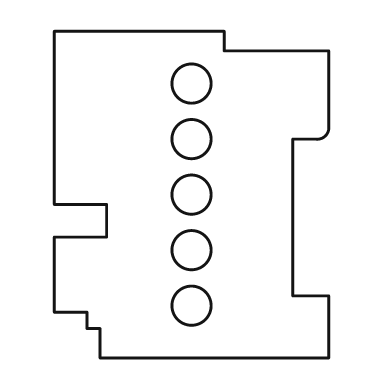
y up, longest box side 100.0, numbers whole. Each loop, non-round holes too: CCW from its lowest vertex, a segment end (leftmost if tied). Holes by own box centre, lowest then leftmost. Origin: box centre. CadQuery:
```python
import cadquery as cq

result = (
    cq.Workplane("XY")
    .moveTo(-28.0, -50.0)
    .lineTo(42.0, -50.0)
    .lineTo(42.0, -31.0)
    .lineTo(31.0, -31.0)
    .lineTo(31.0, 17.0)
    .lineTo(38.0, 17.0)
    .threePointArc((41.0, 18.0), (42.0, 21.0))
    .lineTo(42.0, 44.0)
    .lineTo(10.0, 44.0)
    .lineTo(10.0, 50.0)
    .lineTo(-42.0, 50.0)
    .lineTo(-42.0, -3.0)
    .lineTo(-26.0, -3.0)
    .lineTo(-26.0, -13.0)
    .lineTo(-42.0, -13.0)
    .lineTo(-42.0, -36.0)
    .lineTo(-32.0, -36.0)
    .lineTo(-32.0, -41.0)
    .lineTo(-28.0, -41.0)
    .close()
    .moveTo(0.0, -34.0)
    .circle(6.0)
    .moveTo(0.0, -17.0)
    .circle(6.0)
    .moveTo(0.0, 0.0)
    .circle(6.0)
    .moveTo(0.0, 17.0)
    .circle(6.0)
    .moveTo(0.0, 34.0)
    .circle(6.0)
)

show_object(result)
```